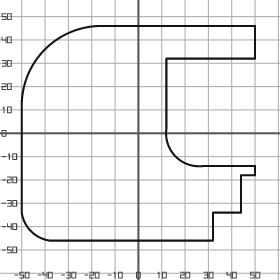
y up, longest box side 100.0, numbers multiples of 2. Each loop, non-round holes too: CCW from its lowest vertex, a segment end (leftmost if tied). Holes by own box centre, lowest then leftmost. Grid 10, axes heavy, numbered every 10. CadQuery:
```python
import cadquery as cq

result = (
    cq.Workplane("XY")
    .moveTo(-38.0, -46.0)
    .lineTo(32.0, -46.0)
    .lineTo(32.0, -34.0)
    .lineTo(44.0, -34.0)
    .lineTo(44.0, -18.0)
    .lineTo(50.0, -18.0)
    .lineTo(50.0, -14.0)
    .lineTo(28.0, -14.0)
    .threePointArc((16.0, -10.0), (12.0, 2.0))
    .lineTo(12.0, 32.0)
    .lineTo(50.0, 32.0)
    .lineTo(50.0, 46.0)
    .lineTo(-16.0, 46.0)
    .threePointArc((-40.0, 36.0), (-50.0, 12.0))
    .lineTo(-50.0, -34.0)
    .threePointArc((-46.0, -42.0), (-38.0, -46.0))
    .close()
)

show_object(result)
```